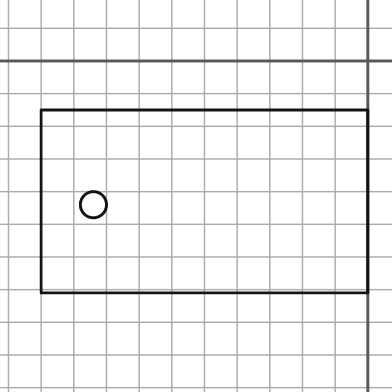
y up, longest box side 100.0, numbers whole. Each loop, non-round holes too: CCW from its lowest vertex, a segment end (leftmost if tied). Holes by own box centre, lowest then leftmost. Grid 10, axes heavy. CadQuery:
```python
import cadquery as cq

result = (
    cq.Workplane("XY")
    .moveTo(-100.0, -71.0)
    .lineTo(0.0, -71.0)
    .lineTo(0.0, -15.0)
    .lineTo(-100.0, -15.0)
    .close()
    .moveTo(-84.0, -44.0)
    .circle(4.0)
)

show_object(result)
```